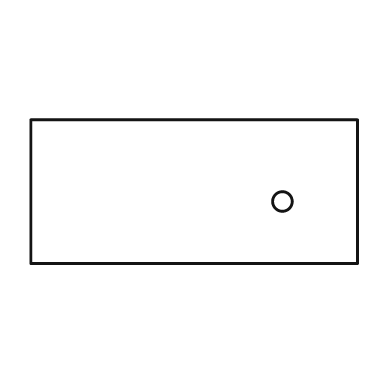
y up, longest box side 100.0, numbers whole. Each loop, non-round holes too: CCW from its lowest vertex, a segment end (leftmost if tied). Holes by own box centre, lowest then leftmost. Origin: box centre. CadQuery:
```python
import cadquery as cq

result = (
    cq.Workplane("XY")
    .moveTo(-50.0, -22.0)
    .lineTo(50.0, -22.0)
    .lineTo(50.0, 22.0)
    .lineTo(-50.0, 22.0)
    .close()
    .moveTo(27.0, -3.0)
    .circle(3.0)
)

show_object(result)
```